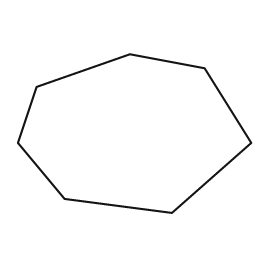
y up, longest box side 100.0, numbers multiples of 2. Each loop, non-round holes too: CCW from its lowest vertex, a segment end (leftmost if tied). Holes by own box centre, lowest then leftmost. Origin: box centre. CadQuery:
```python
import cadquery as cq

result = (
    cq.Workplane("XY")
    .moveTo(16.0, -34.0)
    .lineTo(50.0, -4.0)
    .lineTo(30.0, 28.0)
    .lineTo(-2.0, 34.0)
    .lineTo(-42.0, 20.0)
    .lineTo(-50.0, -4.0)
    .lineTo(-30.0, -28.0)
    .close()
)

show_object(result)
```